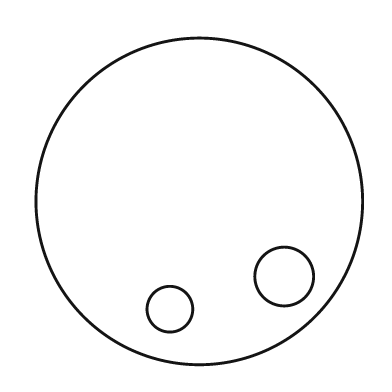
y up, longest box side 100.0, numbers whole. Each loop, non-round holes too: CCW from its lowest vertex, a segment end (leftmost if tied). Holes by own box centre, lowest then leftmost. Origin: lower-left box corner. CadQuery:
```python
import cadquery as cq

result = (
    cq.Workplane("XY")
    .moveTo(50.0, 50.0)
    .circle(50.0)
    .moveTo(41.0, 17.0)
    .circle(7.0)
    .moveTo(76.0, 27.0)
    .circle(9.0)
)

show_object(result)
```